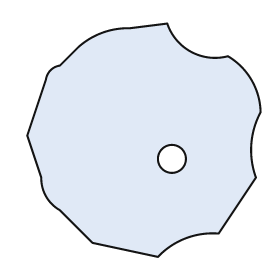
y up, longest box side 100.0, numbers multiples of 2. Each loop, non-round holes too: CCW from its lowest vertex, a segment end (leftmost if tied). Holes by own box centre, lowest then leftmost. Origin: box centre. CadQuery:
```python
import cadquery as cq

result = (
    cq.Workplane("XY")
    .moveTo(6.0, -50.0)
    .threePointArc((18.0, -42.0), (32.0, -40.0))
    .lineTo(48.0, -16.0)
    .threePointArc((46.0, -2.0), (50.0, 12.0))
    .threePointArc((46.0, 26.0), (36.0, 36.0))
    .threePointArc((20.0, 38.0), (10.0, 50.0))
    .lineTo(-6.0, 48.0)
    .threePointArc((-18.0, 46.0), (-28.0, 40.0))
    .lineTo(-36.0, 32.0)
    .threePointArc((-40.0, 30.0), (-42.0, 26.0))
    .lineTo(-50.0, 2.0)
    .lineTo(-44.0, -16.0)
    .threePointArc((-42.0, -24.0), (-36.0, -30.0))
    .lineTo(-22.0, -44.0)
    .close()
    .moveTo(12.0, -8.0)
    .circle(6.0)
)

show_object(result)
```